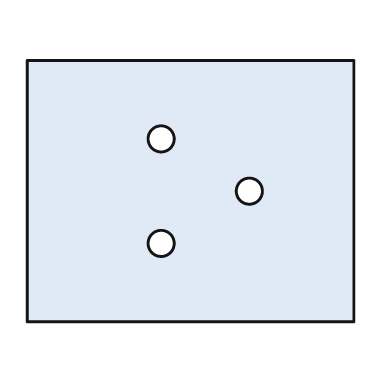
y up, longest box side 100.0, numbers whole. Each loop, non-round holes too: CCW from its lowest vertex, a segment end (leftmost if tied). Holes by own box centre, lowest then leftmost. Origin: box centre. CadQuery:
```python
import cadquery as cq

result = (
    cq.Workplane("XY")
    .moveTo(-50.0, -40.0)
    .lineTo(50.0, -40.0)
    .lineTo(50.0, 40.0)
    .lineTo(-50.0, 40.0)
    .close()
    .moveTo(-9.0, -16.0)
    .circle(4.0)
    .moveTo(18.0, 0.0)
    .circle(4.0)
    .moveTo(-9.0, 16.0)
    .circle(4.0)
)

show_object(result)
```